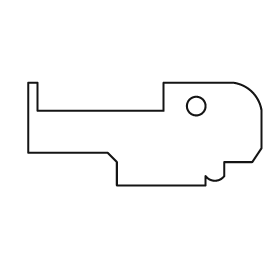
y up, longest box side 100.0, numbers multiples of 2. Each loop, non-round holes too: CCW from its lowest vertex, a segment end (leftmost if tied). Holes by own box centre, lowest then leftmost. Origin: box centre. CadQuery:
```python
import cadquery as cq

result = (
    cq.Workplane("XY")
    .moveTo(-12.0, -22.0)
    .lineTo(26.0, -22.0)
    .lineTo(26.0, -18.0)
    .threePointArc((30.0, -20.0), (34.0, -18.0))
    .lineTo(34.0, -12.0)
    .lineTo(46.0, -12.0)
    .lineTo(50.0, -6.0)
    .lineTo(50.0, 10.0)
    .threePointArc((46.0, 18.0), (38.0, 22.0))
    .lineTo(8.0, 22.0)
    .lineTo(8.0, 10.0)
    .lineTo(-46.0, 10.0)
    .lineTo(-46.0, 22.0)
    .lineTo(-50.0, 22.0)
    .lineTo(-50.0, -8.0)
    .lineTo(-16.0, -8.0)
    .lineTo(-12.0, -12.0)
    .close()
    .moveTo(22.0, 12.0)
    .circle(4.0)
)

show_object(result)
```